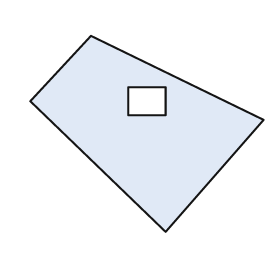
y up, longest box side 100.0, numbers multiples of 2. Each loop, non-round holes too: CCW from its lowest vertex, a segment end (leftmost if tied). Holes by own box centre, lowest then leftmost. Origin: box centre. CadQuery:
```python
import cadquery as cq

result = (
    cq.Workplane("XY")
    .moveTo(8.0, -42.0)
    .lineTo(50.0, 6.0)
    .lineTo(-24.0, 42.0)
    .lineTo(-50.0, 14.0)
    .close()
    .moveTo(-8.0, 8.0)
    .lineTo(8.0, 8.0)
    .lineTo(8.0, 20.0)
    .lineTo(-8.0, 20.0)
    .close()
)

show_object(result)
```